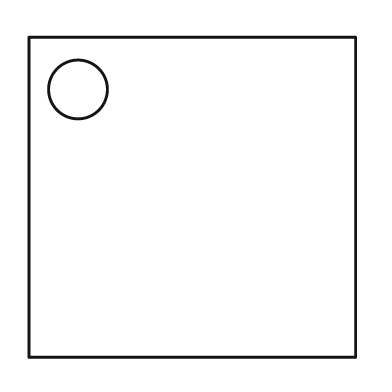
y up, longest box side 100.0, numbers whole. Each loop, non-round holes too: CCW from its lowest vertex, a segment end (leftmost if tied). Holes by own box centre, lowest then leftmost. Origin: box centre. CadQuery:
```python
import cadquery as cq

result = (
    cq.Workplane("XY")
    .moveTo(-50.0, -49.0)
    .lineTo(50.0, -49.0)
    .lineTo(50.0, 49.0)
    .lineTo(-50.0, 49.0)
    .close()
    .moveTo(-35.0, 33.0)
    .circle(9.0)
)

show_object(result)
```